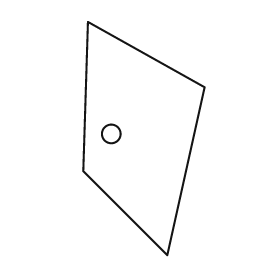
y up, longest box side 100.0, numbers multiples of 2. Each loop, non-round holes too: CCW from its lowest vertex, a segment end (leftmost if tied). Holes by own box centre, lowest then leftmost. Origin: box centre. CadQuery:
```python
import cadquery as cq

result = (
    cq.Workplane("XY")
    .moveTo(10.0, -50.0)
    .lineTo(26.0, 22.0)
    .lineTo(-24.0, 50.0)
    .lineTo(-26.0, -14.0)
    .close()
    .moveTo(-14.0, 2.0)
    .circle(4.0)
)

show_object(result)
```